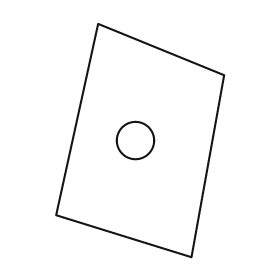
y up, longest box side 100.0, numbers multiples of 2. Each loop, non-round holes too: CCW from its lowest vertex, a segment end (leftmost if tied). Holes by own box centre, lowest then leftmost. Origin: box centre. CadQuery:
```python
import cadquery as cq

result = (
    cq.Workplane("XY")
    .moveTo(22.0, -50.0)
    .lineTo(36.0, 28.0)
    .lineTo(-18.0, 50.0)
    .lineTo(-36.0, -32.0)
    .close()
    .moveTo(-2.0, 0.0)
    .circle(8.0)
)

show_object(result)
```